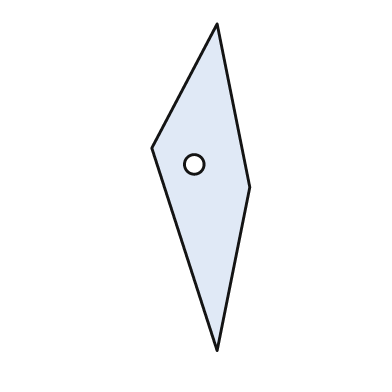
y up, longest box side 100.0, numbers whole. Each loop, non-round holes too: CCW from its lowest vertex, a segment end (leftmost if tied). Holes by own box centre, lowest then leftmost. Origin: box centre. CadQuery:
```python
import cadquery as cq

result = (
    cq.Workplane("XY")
    .moveTo(5.0, -50.0)
    .lineTo(15.0, 0.0)
    .lineTo(5.0, 50.0)
    .lineTo(-15.0, 12.0)
    .close()
    .moveTo(-2.0, 7.0)
    .circle(3.0)
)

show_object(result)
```